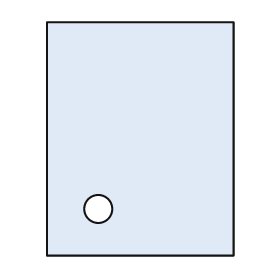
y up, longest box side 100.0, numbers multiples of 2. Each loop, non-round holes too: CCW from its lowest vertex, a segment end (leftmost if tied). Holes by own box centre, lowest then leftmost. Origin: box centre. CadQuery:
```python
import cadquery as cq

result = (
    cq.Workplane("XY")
    .moveTo(-40.0, -50.0)
    .lineTo(40.0, -50.0)
    .lineTo(40.0, 50.0)
    .lineTo(-40.0, 50.0)
    .close()
    .moveTo(-18.0, -30.0)
    .circle(6.0)
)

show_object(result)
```